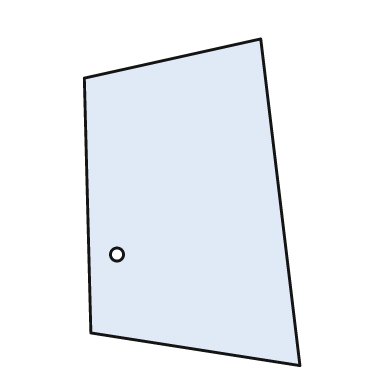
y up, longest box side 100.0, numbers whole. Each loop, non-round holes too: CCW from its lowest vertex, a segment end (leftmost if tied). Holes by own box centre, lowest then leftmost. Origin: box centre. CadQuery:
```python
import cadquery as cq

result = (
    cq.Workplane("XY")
    .moveTo(33.0, -50.0)
    .lineTo(21.0, 50.0)
    .lineTo(-33.0, 38.0)
    .lineTo(-31.0, -40.0)
    .close()
    .moveTo(-23.0, -16.0)
    .circle(2.0)
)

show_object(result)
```